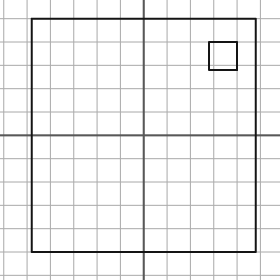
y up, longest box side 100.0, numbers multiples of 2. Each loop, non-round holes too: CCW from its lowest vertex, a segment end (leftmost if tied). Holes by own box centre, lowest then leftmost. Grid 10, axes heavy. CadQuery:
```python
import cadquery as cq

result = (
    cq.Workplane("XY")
    .moveTo(-48.0, -50.0)
    .lineTo(48.0, -50.0)
    .lineTo(48.0, 50.0)
    .lineTo(-48.0, 50.0)
    .close()
    .moveTo(28.0, 28.0)
    .lineTo(40.0, 28.0)
    .lineTo(40.0, 40.0)
    .lineTo(28.0, 40.0)
    .close()
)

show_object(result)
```